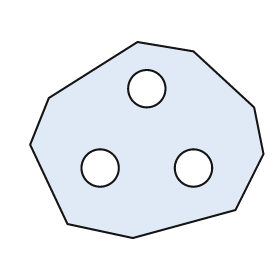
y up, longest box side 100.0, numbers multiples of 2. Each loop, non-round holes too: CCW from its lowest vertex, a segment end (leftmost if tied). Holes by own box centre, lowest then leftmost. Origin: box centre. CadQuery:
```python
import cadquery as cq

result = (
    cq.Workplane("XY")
    .moveTo(-6.0, -42.0)
    .lineTo(38.0, -30.0)
    .lineTo(50.0, -6.0)
    .lineTo(46.0, 14.0)
    .lineTo(20.0, 38.0)
    .lineTo(-4.0, 42.0)
    .lineTo(-42.0, 18.0)
    .lineTo(-50.0, -2.0)
    .lineTo(-34.0, -36.0)
    .close()
    .moveTo(-20.0, -12.0)
    .circle(8.0)
    .moveTo(20.0, -12.0)
    .circle(8.0)
    .moveTo(0.0, 22.0)
    .circle(8.0)
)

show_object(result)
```